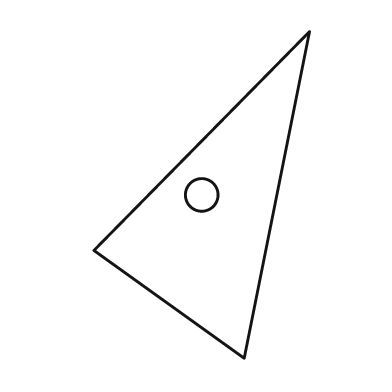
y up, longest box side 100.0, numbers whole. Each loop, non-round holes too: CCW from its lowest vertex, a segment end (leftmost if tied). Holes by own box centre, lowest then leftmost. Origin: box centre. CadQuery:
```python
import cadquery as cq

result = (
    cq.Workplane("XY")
    .moveTo(13.0, -50.0)
    .lineTo(33.0, 50.0)
    .lineTo(-33.0, -17.0)
    .close()
    .moveTo(0.0, 0.0)
    .circle(5.0)
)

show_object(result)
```